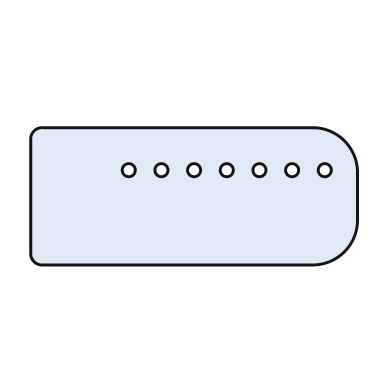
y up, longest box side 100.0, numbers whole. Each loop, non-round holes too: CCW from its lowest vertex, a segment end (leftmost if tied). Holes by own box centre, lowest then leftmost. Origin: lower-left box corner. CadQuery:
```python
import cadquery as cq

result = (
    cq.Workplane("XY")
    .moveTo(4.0, 0.0)
    .lineTo(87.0, 0.0)
    .threePointArc((96.0, 4.0), (100.0, 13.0))
    .lineTo(100.0, 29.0)
    .threePointArc((96.0, 38.0), (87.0, 42.0))
    .lineTo(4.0, 42.0)
    .threePointArc((1.0, 41.0), (0.0, 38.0))
    .lineTo(0.0, 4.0)
    .threePointArc((1.0, 1.0), (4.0, 0.0))
    .close()
    .moveTo(30.0, 29.0)
    .circle(2.0)
    .moveTo(40.0, 29.0)
    .circle(2.0)
    .moveTo(50.0, 29.0)
    .circle(2.0)
    .moveTo(60.0, 29.0)
    .circle(2.0)
    .moveTo(70.0, 29.0)
    .circle(2.0)
    .moveTo(80.0, 29.0)
    .circle(2.0)
    .moveTo(90.0, 29.0)
    .circle(2.0)
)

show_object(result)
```